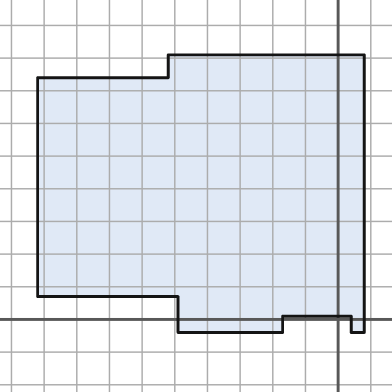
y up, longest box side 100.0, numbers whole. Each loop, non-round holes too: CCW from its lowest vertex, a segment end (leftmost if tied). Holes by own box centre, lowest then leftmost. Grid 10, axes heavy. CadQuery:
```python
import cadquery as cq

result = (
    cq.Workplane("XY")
    .moveTo(-49.0, -4.0)
    .lineTo(-17.0, -4.0)
    .lineTo(-17.0, 1.0)
    .lineTo(4.0, 1.0)
    .lineTo(4.0, -4.0)
    .lineTo(8.0, -4.0)
    .lineTo(8.0, 81.0)
    .lineTo(-52.0, 81.0)
    .lineTo(-52.0, 74.0)
    .lineTo(-92.0, 74.0)
    .lineTo(-92.0, 7.0)
    .lineTo(-49.0, 7.0)
    .close()
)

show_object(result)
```